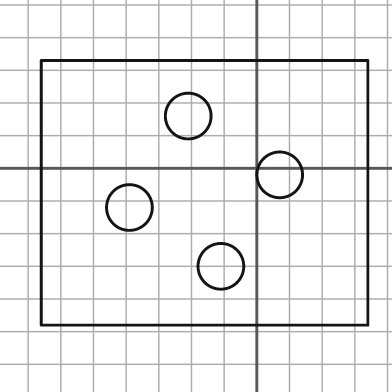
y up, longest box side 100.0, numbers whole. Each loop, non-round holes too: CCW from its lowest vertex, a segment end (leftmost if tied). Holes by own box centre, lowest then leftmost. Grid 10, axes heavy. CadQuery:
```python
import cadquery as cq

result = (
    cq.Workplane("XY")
    .moveTo(-66.0, -48.0)
    .lineTo(34.0, -48.0)
    .lineTo(34.0, 33.0)
    .lineTo(-66.0, 33.0)
    .close()
    .moveTo(-11.0, -30.0)
    .circle(7.0)
    .moveTo(-39.0, -12.0)
    .circle(7.0)
    .moveTo(7.0, -2.0)
    .circle(7.0)
    .moveTo(-21.0, 16.0)
    .circle(7.0)
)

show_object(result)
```